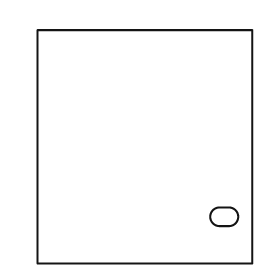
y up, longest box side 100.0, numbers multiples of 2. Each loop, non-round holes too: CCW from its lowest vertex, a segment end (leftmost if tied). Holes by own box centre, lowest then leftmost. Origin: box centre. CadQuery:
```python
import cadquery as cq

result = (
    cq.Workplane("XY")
    .moveTo(-46.0, -50.0)
    .lineTo(46.0, -50.0)
    .lineTo(46.0, 50.0)
    .lineTo(-46.0, 50.0)
    .close()
    .moveTo(32.0, -34.0)
    .lineTo(36.0, -34.0)
    .threePointArc((40.0, -30.0), (36.0, -26.0))
    .lineTo(32.0, -26.0)
    .threePointArc((28.0, -30.0), (32.0, -34.0))
    .close()
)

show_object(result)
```